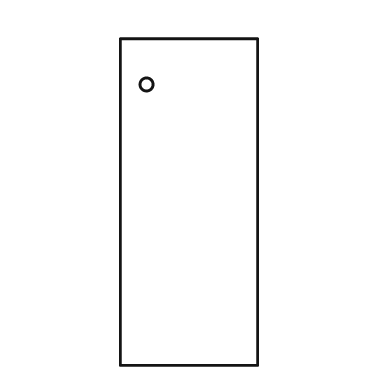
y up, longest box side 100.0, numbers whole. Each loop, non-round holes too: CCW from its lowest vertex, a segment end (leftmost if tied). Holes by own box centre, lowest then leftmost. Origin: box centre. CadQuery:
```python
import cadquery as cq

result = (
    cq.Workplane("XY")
    .moveTo(-21.0, -50.0)
    .lineTo(21.0, -50.0)
    .lineTo(21.0, 50.0)
    .lineTo(-21.0, 50.0)
    .close()
    .moveTo(-13.0, 36.0)
    .circle(2.0)
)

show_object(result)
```